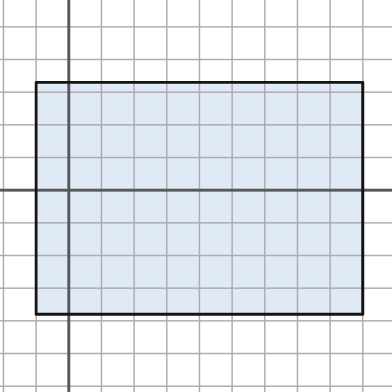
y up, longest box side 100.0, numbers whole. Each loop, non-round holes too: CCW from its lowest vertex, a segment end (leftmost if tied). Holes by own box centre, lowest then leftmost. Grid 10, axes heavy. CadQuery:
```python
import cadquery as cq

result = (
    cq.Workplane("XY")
    .moveTo(-10.0, -38.0)
    .lineTo(90.0, -38.0)
    .lineTo(90.0, 33.0)
    .lineTo(-10.0, 33.0)
    .close()
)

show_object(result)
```